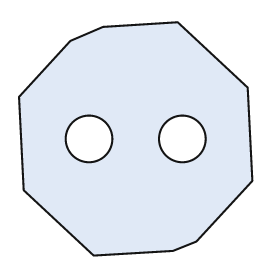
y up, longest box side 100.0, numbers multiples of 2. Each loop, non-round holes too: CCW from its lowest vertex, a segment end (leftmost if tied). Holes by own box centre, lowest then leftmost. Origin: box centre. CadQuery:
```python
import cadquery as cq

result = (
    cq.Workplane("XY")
    .moveTo(-18.0, -50.0)
    .lineTo(16.0, -48.0)
    .lineTo(26.0, -44.0)
    .lineTo(50.0, -18.0)
    .lineTo(48.0, 22.0)
    .lineTo(18.0, 50.0)
    .lineTo(-14.0, 48.0)
    .lineTo(-28.0, 42.0)
    .lineTo(-50.0, 18.0)
    .lineTo(-48.0, -22.0)
    .close()
    .moveTo(-20.0, 0.0)
    .circle(10.0)
    .moveTo(20.0, 0.0)
    .circle(10.0)
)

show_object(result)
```